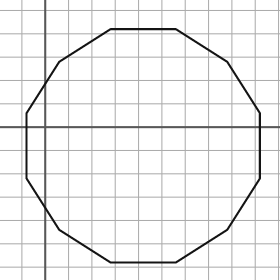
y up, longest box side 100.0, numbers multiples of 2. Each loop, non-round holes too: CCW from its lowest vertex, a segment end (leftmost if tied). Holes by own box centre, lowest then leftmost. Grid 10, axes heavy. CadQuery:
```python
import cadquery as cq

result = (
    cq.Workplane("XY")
    .moveTo(28.0, -58.0)
    .lineTo(56.0, -58.0)
    .lineTo(78.0, -44.0)
    .lineTo(92.0, -22.0)
    .lineTo(92.0, 6.0)
    .lineTo(78.0, 28.0)
    .lineTo(56.0, 42.0)
    .lineTo(28.0, 42.0)
    .lineTo(6.0, 28.0)
    .lineTo(-8.0, 6.0)
    .lineTo(-8.0, -22.0)
    .lineTo(6.0, -44.0)
    .close()
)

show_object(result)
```